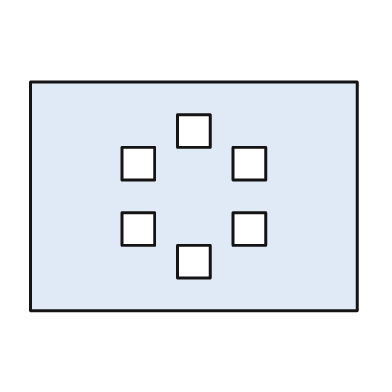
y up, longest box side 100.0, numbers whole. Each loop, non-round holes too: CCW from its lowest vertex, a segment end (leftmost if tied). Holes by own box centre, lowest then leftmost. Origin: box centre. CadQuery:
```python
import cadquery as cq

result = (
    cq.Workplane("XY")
    .moveTo(-50.0, -35.0)
    .lineTo(50.0, -35.0)
    .lineTo(50.0, 35.0)
    .lineTo(-50.0, 35.0)
    .close()
    .moveTo(-5.0, -25.0)
    .lineTo(5.0, -25.0)
    .lineTo(5.0, -15.0)
    .lineTo(-5.0, -15.0)
    .close()
    .moveTo(-22.0, -15.0)
    .lineTo(-12.0, -15.0)
    .lineTo(-12.0, -5.0)
    .lineTo(-22.0, -5.0)
    .close()
    .moveTo(12.0, -15.0)
    .lineTo(22.0, -15.0)
    .lineTo(22.0, -5.0)
    .lineTo(12.0, -5.0)
    .close()
    .moveTo(-22.0, 5.0)
    .lineTo(-12.0, 5.0)
    .lineTo(-12.0, 15.0)
    .lineTo(-22.0, 15.0)
    .close()
    .moveTo(12.0, 5.0)
    .lineTo(22.0, 5.0)
    .lineTo(22.0, 15.0)
    .lineTo(12.0, 15.0)
    .close()
    .moveTo(-5.0, 15.0)
    .lineTo(5.0, 15.0)
    .lineTo(5.0, 25.0)
    .lineTo(-5.0, 25.0)
    .close()
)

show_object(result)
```